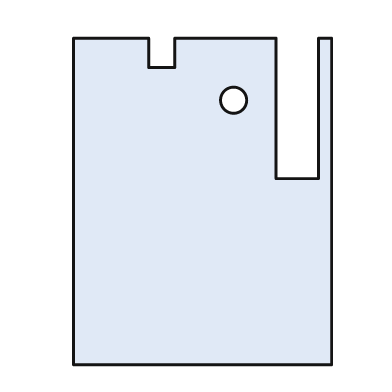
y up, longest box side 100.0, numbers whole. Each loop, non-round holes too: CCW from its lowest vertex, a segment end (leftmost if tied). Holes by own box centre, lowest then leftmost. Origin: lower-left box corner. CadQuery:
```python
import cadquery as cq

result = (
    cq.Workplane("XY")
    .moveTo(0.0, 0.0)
    .lineTo(79.0, 0.0)
    .lineTo(79.0, 100.0)
    .lineTo(75.0, 100.0)
    .lineTo(75.0, 57.0)
    .lineTo(62.0, 57.0)
    .lineTo(62.0, 100.0)
    .lineTo(31.0, 100.0)
    .lineTo(31.0, 91.0)
    .lineTo(23.0, 91.0)
    .lineTo(23.0, 100.0)
    .lineTo(0.0, 100.0)
    .close()
    .moveTo(49.0, 81.0)
    .circle(4.0)
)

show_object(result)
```